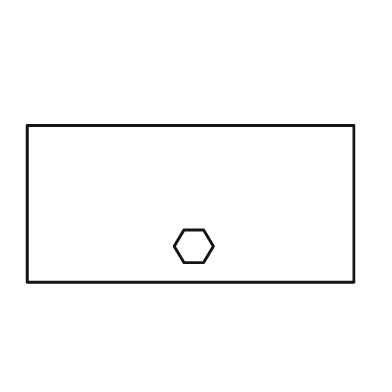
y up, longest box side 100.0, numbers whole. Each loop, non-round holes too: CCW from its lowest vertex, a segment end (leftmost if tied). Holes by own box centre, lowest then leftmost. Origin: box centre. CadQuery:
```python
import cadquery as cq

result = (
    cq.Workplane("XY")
    .moveTo(-50.0, -24.0)
    .lineTo(50.0, -24.0)
    .lineTo(50.0, 24.0)
    .lineTo(-50.0, 24.0)
    .close()
    .moveTo(-2.0, -18.0)
    .lineTo(4.0, -18.0)
    .lineTo(7.0, -13.0)
    .lineTo(4.0, -8.0)
    .lineTo(-2.0, -8.0)
    .lineTo(-5.0, -13.0)
    .close()
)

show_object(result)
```